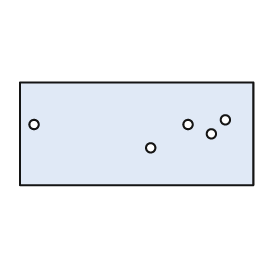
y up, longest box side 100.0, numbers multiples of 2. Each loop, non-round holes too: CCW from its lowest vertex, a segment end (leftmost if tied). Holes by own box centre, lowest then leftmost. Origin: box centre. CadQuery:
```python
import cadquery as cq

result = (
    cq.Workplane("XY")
    .moveTo(-50.0, -22.0)
    .lineTo(50.0, -22.0)
    .lineTo(50.0, 22.0)
    .lineTo(-50.0, 22.0)
    .close()
    .moveTo(6.0, -6.0)
    .circle(2.0)
    .moveTo(32.0, 0.0)
    .circle(2.0)
    .moveTo(-44.0, 4.0)
    .circle(2.0)
    .moveTo(22.0, 4.0)
    .circle(2.0)
    .moveTo(38.0, 6.0)
    .circle(2.0)
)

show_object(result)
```